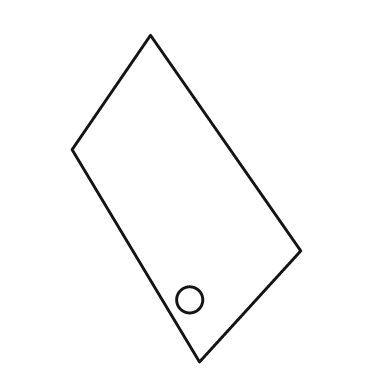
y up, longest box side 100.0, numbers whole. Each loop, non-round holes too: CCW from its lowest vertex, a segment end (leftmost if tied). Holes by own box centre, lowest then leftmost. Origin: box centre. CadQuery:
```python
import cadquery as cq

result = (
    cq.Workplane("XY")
    .moveTo(4.0, -50.0)
    .lineTo(35.0, -16.0)
    .lineTo(-11.0, 50.0)
    .lineTo(-35.0, 15.0)
    .close()
    .moveTo(1.0, -31.0)
    .circle(4.0)
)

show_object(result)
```